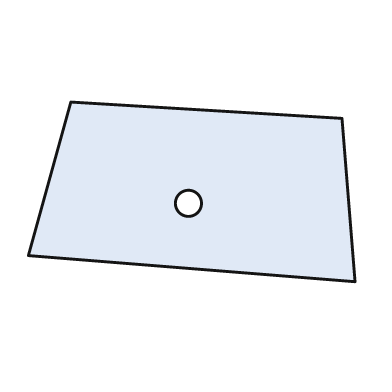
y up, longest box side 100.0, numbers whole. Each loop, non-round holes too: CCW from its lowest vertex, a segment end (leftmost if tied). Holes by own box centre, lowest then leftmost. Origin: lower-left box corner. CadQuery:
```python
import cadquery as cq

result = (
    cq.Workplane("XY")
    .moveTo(100.0, 0.0)
    .lineTo(96.0, 50.0)
    .lineTo(13.0, 55.0)
    .lineTo(0.0, 8.0)
    .close()
    .moveTo(49.0, 24.0)
    .circle(4.0)
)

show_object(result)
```